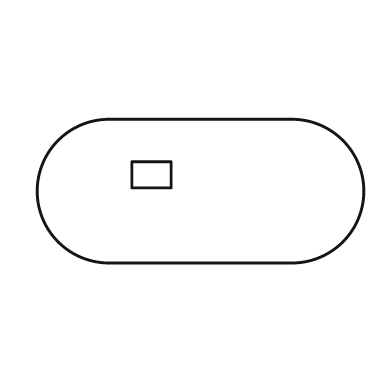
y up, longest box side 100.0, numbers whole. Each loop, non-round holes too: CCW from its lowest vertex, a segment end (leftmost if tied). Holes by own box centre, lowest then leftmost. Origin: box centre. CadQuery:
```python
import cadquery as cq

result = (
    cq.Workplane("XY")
    .moveTo(-28.0, -22.0)
    .lineTo(28.0, -22.0)
    .threePointArc((50.0, 0.0), (28.0, 22.0))
    .lineTo(-28.0, 22.0)
    .threePointArc((-50.0, 0.0), (-28.0, -22.0))
    .close()
    .moveTo(-21.0, 1.0)
    .lineTo(-9.0, 1.0)
    .lineTo(-9.0, 9.0)
    .lineTo(-21.0, 9.0)
    .close()
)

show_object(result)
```